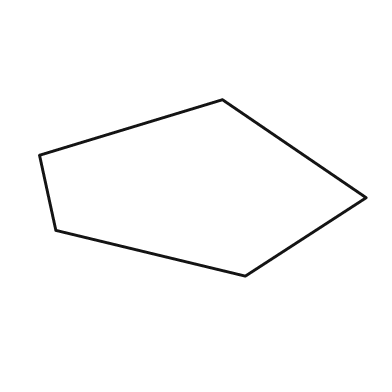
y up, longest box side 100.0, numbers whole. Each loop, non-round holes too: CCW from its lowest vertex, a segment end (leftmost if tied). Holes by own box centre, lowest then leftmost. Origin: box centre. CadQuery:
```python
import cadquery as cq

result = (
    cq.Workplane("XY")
    .moveTo(13.0, -27.0)
    .lineTo(50.0, -3.0)
    .lineTo(6.0, 27.0)
    .lineTo(-50.0, 10.0)
    .lineTo(-45.0, -13.0)
    .close()
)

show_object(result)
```